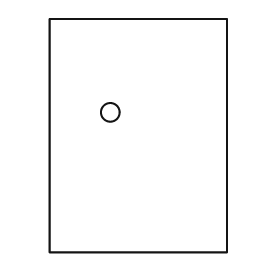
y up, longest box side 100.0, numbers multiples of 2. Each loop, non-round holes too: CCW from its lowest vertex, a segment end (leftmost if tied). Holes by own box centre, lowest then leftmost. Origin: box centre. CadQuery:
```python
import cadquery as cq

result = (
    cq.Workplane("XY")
    .moveTo(-38.0, -50.0)
    .lineTo(38.0, -50.0)
    .lineTo(38.0, 50.0)
    .lineTo(-38.0, 50.0)
    .close()
    .moveTo(-12.0, 10.0)
    .circle(4.0)
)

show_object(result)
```